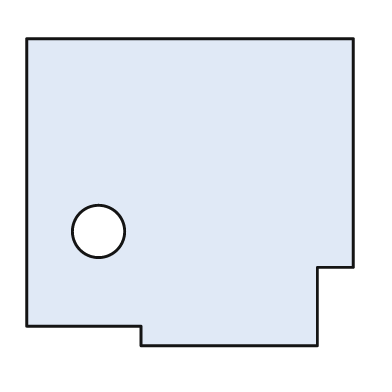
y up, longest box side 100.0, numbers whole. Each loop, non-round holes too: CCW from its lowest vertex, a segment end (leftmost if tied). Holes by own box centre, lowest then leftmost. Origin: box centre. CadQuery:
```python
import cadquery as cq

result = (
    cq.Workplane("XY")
    .moveTo(-15.0, -47.0)
    .lineTo(39.0, -47.0)
    .lineTo(39.0, -23.0)
    .lineTo(50.0, -23.0)
    .lineTo(50.0, 47.0)
    .lineTo(-50.0, 47.0)
    .lineTo(-50.0, -41.0)
    .lineTo(-15.0, -41.0)
    .close()
    .moveTo(-28.0, -12.0)
    .circle(8.0)
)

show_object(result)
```